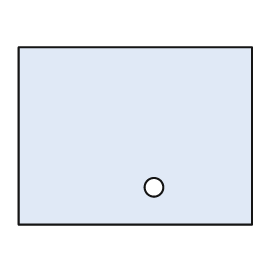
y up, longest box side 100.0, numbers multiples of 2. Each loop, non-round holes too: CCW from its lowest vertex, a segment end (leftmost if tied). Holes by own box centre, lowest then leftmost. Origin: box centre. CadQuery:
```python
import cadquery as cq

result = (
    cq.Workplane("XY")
    .moveTo(-50.0, -38.0)
    .lineTo(50.0, -38.0)
    .lineTo(50.0, 38.0)
    .lineTo(-50.0, 38.0)
    .close()
    .moveTo(8.0, -22.0)
    .circle(4.0)
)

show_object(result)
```